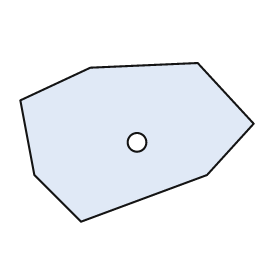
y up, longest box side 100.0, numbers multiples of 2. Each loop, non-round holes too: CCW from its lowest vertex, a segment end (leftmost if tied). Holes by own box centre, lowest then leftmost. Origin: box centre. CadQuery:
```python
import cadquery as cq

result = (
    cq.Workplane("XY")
    .moveTo(-24.0, -34.0)
    .lineTo(30.0, -14.0)
    .lineTo(50.0, 8.0)
    .lineTo(26.0, 34.0)
    .lineTo(-20.0, 32.0)
    .lineTo(-50.0, 18.0)
    .lineTo(-44.0, -14.0)
    .close()
    .moveTo(0.0, 0.0)
    .circle(4.0)
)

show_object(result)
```